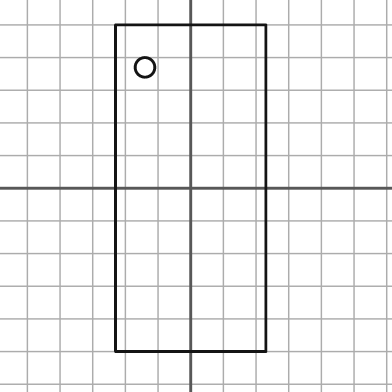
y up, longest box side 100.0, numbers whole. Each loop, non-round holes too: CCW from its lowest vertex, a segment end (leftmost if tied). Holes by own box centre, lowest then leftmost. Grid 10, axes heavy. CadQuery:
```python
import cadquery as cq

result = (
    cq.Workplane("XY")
    .moveTo(-23.0, -50.0)
    .lineTo(23.0, -50.0)
    .lineTo(23.0, 50.0)
    .lineTo(-23.0, 50.0)
    .close()
    .moveTo(-14.0, 37.0)
    .circle(3.0)
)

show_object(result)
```